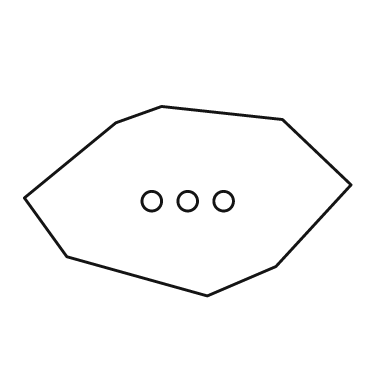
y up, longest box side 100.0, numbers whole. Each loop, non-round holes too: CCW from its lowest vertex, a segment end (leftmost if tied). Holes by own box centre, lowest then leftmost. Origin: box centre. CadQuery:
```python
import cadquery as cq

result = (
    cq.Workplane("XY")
    .moveTo(6.0, -29.0)
    .lineTo(27.0, -20.0)
    .lineTo(50.0, 5.0)
    .lineTo(29.0, 25.0)
    .lineTo(-8.0, 29.0)
    .lineTo(-22.0, 24.0)
    .lineTo(-50.0, 1.0)
    .lineTo(-37.0, -17.0)
    .close()
    .moveTo(-11.0, 0.0)
    .circle(3.0)
    .moveTo(0.0, 0.0)
    .circle(3.0)
    .moveTo(11.0, 0.0)
    .circle(3.0)
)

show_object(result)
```